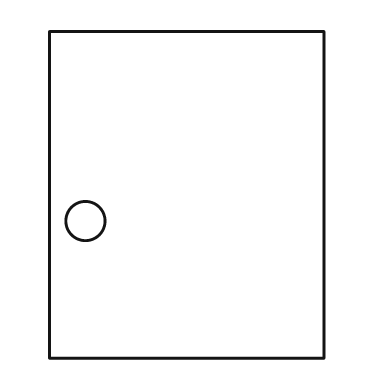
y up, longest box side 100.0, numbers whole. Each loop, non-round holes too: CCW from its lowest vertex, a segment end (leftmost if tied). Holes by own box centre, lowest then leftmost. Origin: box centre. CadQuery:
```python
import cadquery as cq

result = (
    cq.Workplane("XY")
    .moveTo(-42.0, -50.0)
    .lineTo(42.0, -50.0)
    .lineTo(42.0, 50.0)
    .lineTo(-42.0, 50.0)
    .close()
    .moveTo(-31.0, -8.0)
    .circle(6.0)
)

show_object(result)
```